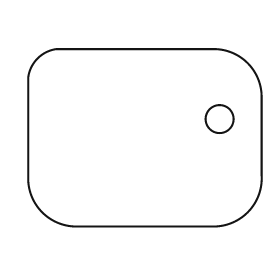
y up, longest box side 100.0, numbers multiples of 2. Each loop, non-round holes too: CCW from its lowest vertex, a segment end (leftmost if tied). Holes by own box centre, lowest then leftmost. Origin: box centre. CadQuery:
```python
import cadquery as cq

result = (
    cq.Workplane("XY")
    .moveTo(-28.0, -38.0)
    .lineTo(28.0, -38.0)
    .threePointArc((44.0, -32.0), (50.0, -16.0))
    .lineTo(50.0, 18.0)
    .threePointArc((44.0, 32.0), (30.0, 38.0))
    .lineTo(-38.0, 38.0)
    .threePointArc((-46.0, 34.0), (-50.0, 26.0))
    .lineTo(-50.0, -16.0)
    .threePointArc((-44.0, -32.0), (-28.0, -38.0))
    .close()
    .moveTo(32.0, 8.0)
    .circle(6.0)
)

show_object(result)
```